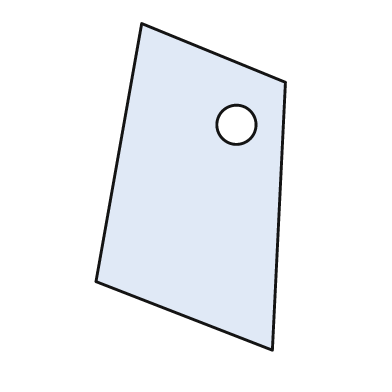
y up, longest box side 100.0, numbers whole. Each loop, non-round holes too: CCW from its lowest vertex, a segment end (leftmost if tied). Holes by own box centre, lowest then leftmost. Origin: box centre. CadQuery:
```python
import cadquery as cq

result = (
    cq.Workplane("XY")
    .moveTo(25.0, -50.0)
    .lineTo(29.0, 32.0)
    .lineTo(-15.0, 50.0)
    .lineTo(-29.0, -29.0)
    .close()
    .moveTo(14.0, 19.0)
    .circle(6.0)
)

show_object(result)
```